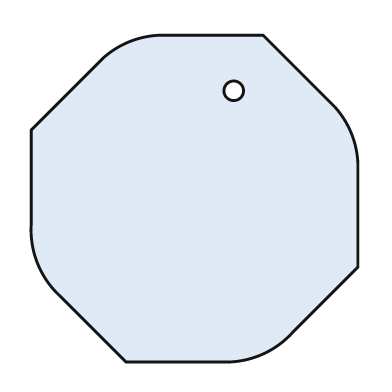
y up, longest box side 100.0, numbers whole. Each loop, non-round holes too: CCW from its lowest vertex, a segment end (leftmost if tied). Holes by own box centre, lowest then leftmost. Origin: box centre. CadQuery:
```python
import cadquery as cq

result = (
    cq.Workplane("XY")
    .moveTo(-21.0, -50.0)
    .lineTo(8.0, -50.0)
    .threePointArc((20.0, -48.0), (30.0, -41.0))
    .lineTo(50.0, -21.0)
    .lineTo(50.0, 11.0)
    .threePointArc((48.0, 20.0), (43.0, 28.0))
    .lineTo(21.0, 50.0)
    .lineTo(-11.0, 50.0)
    .threePointArc((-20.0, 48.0), (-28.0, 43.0))
    .lineTo(-50.0, 21.0)
    .lineTo(-50.0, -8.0)
    .threePointArc((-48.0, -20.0), (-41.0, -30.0))
    .close()
    .moveTo(12.0, 33.0)
    .circle(3.0)
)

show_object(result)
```